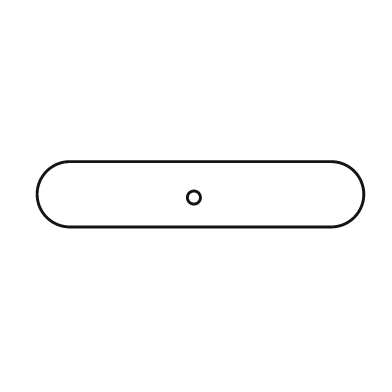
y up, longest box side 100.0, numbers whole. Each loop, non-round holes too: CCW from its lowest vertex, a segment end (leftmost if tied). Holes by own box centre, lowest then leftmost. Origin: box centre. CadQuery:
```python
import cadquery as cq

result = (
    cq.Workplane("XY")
    .moveTo(-40.0, -10.0)
    .lineTo(40.0, -10.0)
    .threePointArc((50.0, 0.0), (40.0, 10.0))
    .lineTo(-40.0, 10.0)
    .threePointArc((-50.0, 0.0), (-40.0, -10.0))
    .close()
    .moveTo(-2.0, -1.0)
    .circle(2.0)
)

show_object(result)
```